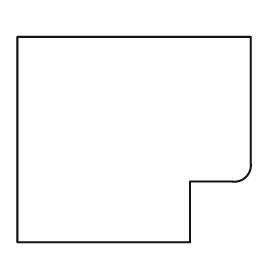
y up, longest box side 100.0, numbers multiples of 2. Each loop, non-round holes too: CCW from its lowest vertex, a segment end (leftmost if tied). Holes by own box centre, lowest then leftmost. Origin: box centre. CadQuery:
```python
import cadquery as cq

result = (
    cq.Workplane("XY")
    .moveTo(-50.0, -44.0)
    .lineTo(24.0, -44.0)
    .lineTo(24.0, -18.0)
    .lineTo(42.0, -18.0)
    .threePointArc((48.0, -16.0), (50.0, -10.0))
    .lineTo(50.0, 44.0)
    .lineTo(-50.0, 44.0)
    .close()
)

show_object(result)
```